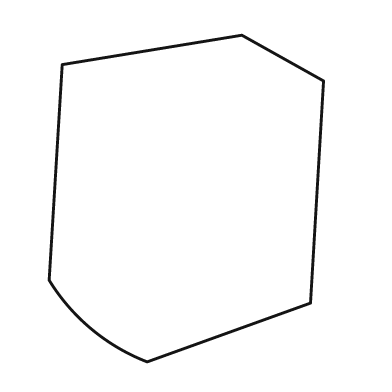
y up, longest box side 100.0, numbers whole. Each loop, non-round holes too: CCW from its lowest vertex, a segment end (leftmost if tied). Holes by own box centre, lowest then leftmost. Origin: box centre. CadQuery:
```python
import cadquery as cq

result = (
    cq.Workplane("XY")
    .moveTo(-12.0, -50.0)
    .lineTo(38.0, -32.0)
    .lineTo(42.0, 36.0)
    .lineTo(17.0, 50.0)
    .lineTo(-38.0, 41.0)
    .lineTo(-42.0, -25.0)
    .threePointArc((-29.0, -40.0), (-12.0, -50.0))
    .close()
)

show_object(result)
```